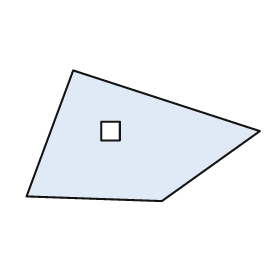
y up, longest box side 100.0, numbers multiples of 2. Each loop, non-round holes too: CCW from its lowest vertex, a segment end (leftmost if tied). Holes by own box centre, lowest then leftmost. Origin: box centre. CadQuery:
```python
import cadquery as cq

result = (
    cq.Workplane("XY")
    .moveTo(8.0, -28.0)
    .lineTo(50.0, 2.0)
    .lineTo(-30.0, 28.0)
    .lineTo(-50.0, -26.0)
    .close()
    .moveTo(-18.0, -2.0)
    .lineTo(-10.0, -2.0)
    .lineTo(-10.0, 6.0)
    .lineTo(-18.0, 6.0)
    .close()
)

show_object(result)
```